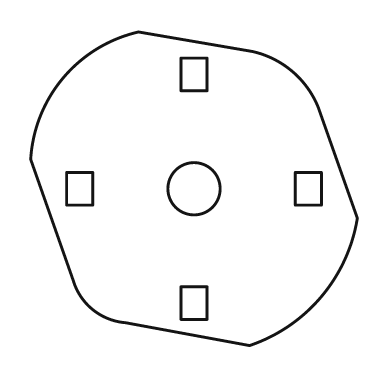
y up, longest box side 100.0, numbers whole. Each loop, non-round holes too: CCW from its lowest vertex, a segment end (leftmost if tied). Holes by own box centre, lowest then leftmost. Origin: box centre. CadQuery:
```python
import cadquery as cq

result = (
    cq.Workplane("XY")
    .moveTo(17.0, -48.0)
    .threePointArc((39.0, -33.0), (50.0, -9.0))
    .lineTo(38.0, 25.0)
    .threePointArc((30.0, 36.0), (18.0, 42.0))
    .lineTo(-17.0, 48.0)
    .threePointArc((-40.0, 34.0), (-50.0, 9.0))
    .lineTo(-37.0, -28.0)
    .threePointArc((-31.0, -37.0), (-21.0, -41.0))
    .close()
    .moveTo(-4.0, -40.0)
    .lineTo(4.0, -40.0)
    .lineTo(4.0, -30.0)
    .lineTo(-4.0, -30.0)
    .close()
    .moveTo(-39.0, -5.0)
    .lineTo(-31.0, -5.0)
    .lineTo(-31.0, 5.0)
    .lineTo(-39.0, 5.0)
    .close()
    .moveTo(0.0, 0.0)
    .circle(8.0)
    .moveTo(31.0, -5.0)
    .lineTo(39.0, -5.0)
    .lineTo(39.0, 5.0)
    .lineTo(31.0, 5.0)
    .close()
    .moveTo(-4.0, 30.0)
    .lineTo(4.0, 30.0)
    .lineTo(4.0, 40.0)
    .lineTo(-4.0, 40.0)
    .close()
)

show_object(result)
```